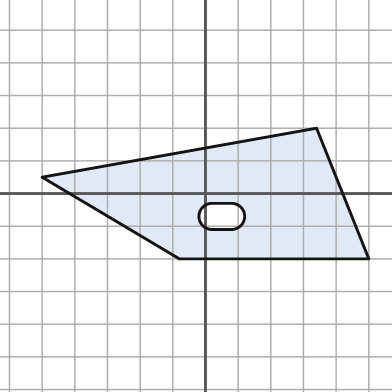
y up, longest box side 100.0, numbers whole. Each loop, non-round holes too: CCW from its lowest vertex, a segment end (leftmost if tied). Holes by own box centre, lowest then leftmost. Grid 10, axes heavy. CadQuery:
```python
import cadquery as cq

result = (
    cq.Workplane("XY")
    .moveTo(-8.0, -20.0)
    .lineTo(50.0, -20.0)
    .lineTo(34.0, 20.0)
    .lineTo(-50.0, 5.0)
    .close()
    .moveTo(2.0, -11.0)
    .lineTo(8.0, -11.0)
    .threePointArc((12.0, -7.0), (8.0, -3.0))
    .lineTo(2.0, -3.0)
    .threePointArc((-2.0, -7.0), (2.0, -11.0))
    .close()
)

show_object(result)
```